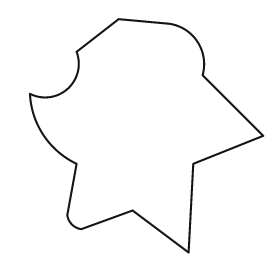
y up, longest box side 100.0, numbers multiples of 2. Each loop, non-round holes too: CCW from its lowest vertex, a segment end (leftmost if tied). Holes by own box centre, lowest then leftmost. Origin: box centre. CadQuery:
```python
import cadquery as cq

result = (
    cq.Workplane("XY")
    .moveTo(18.0, -50.0)
    .lineTo(20.0, -12.0)
    .lineTo(50.0, 0.0)
    .lineTo(24.0, 26.0)
    .threePointArc((22.0, 40.0), (10.0, 48.0))
    .lineTo(-12.0, 50.0)
    .lineTo(-30.0, 36.0)
    .threePointArc((-34.0, 20.0), (-50.0, 18.0))
    .threePointArc((-44.0, 0.0), (-30.0, -12.0))
    .lineTo(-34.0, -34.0)
    .threePointArc((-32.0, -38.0), (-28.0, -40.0))
    .lineTo(-6.0, -32.0)
    .close()
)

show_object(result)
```